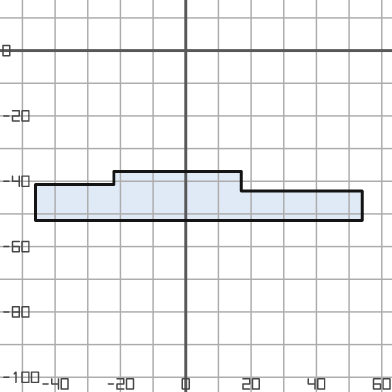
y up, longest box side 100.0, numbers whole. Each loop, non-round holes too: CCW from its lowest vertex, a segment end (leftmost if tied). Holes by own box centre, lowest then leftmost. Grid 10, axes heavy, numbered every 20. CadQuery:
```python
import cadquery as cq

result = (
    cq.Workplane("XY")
    .moveTo(-46.0, -52.0)
    .lineTo(54.0, -52.0)
    .lineTo(54.0, -43.0)
    .lineTo(17.0, -43.0)
    .lineTo(17.0, -37.0)
    .lineTo(-22.0, -37.0)
    .lineTo(-22.0, -41.0)
    .lineTo(-46.0, -41.0)
    .close()
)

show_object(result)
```